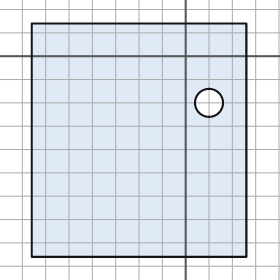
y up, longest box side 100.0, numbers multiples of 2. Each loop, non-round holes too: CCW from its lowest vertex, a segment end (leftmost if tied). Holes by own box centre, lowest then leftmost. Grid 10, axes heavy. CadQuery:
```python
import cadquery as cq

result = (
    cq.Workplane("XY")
    .moveTo(-66.0, -86.0)
    .lineTo(26.0, -86.0)
    .lineTo(26.0, 14.0)
    .lineTo(-66.0, 14.0)
    .close()
    .moveTo(10.0, -20.0)
    .circle(6.0)
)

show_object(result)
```